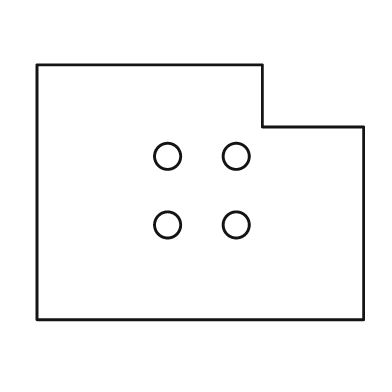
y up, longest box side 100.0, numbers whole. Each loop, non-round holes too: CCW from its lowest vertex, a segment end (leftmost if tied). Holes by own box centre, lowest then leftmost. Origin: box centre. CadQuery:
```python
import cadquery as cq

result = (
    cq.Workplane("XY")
    .moveTo(-50.0, -39.0)
    .lineTo(50.0, -39.0)
    .lineTo(50.0, 20.0)
    .lineTo(19.0, 20.0)
    .lineTo(19.0, 39.0)
    .lineTo(-50.0, 39.0)
    .close()
    .moveTo(-10.0, -10.0)
    .circle(4.0)
    .moveTo(11.0, -10.0)
    .circle(4.0)
    .moveTo(-10.0, 11.0)
    .circle(4.0)
    .moveTo(11.0, 11.0)
    .circle(4.0)
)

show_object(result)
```